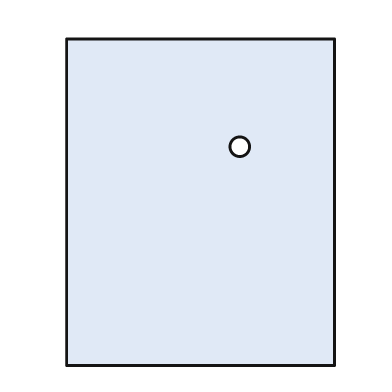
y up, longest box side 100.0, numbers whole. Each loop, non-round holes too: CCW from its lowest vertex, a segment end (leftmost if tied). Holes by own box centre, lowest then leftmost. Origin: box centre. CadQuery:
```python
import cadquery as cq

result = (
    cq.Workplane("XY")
    .moveTo(-41.0, -50.0)
    .lineTo(41.0, -50.0)
    .lineTo(41.0, 50.0)
    .lineTo(-41.0, 50.0)
    .close()
    .moveTo(12.0, 17.0)
    .circle(3.0)
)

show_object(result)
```